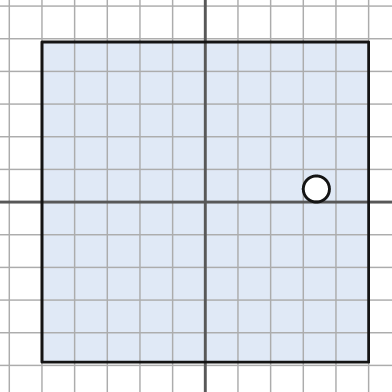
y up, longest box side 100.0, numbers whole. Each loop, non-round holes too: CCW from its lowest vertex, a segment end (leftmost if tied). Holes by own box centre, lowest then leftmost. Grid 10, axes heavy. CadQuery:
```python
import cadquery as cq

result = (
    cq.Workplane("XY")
    .moveTo(-50.0, -49.0)
    .lineTo(50.0, -49.0)
    .lineTo(50.0, 49.0)
    .lineTo(-50.0, 49.0)
    .close()
    .moveTo(34.0, 4.0)
    .circle(4.0)
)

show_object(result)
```